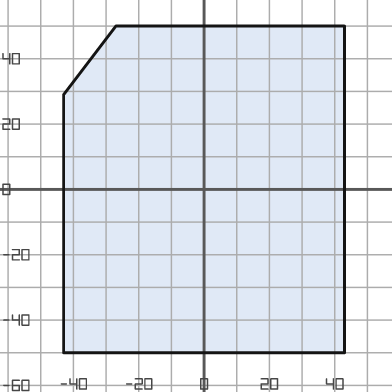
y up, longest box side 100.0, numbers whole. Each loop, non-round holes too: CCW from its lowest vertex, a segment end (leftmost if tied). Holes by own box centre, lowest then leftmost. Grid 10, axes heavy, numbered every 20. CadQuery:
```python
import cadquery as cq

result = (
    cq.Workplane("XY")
    .moveTo(-43.0, -50.0)
    .lineTo(43.0, -50.0)
    .lineTo(43.0, 50.0)
    .lineTo(-27.0, 50.0)
    .lineTo(-43.0, 29.0)
    .close()
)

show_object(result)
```